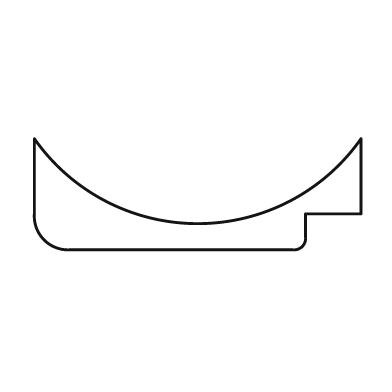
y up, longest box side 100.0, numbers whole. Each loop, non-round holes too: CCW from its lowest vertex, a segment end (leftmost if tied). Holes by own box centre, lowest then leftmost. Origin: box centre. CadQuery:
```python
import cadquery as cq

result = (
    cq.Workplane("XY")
    .moveTo(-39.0, -17.0)
    .lineTo(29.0, -17.0)
    .threePointArc((32.0, -16.0), (33.0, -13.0))
    .lineTo(33.0, -6.0)
    .lineTo(50.0, -6.0)
    .lineTo(50.0, 17.0)
    .threePointArc((0.0, -9.0), (-50.0, 17.0))
    .lineTo(-50.0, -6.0)
    .threePointArc((-47.0, -14.0), (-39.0, -17.0))
    .close()
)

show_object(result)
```